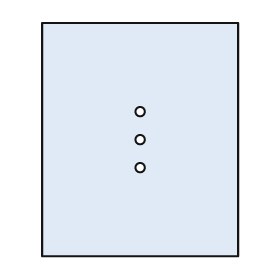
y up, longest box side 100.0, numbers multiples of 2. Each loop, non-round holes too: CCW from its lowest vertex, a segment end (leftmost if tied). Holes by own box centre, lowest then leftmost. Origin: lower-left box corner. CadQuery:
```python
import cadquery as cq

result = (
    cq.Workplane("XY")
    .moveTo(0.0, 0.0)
    .lineTo(84.0, 0.0)
    .lineTo(84.0, 100.0)
    .lineTo(0.0, 100.0)
    .close()
    .moveTo(42.0, 38.0)
    .circle(2.0)
    .moveTo(42.0, 50.0)
    .circle(2.0)
    .moveTo(42.0, 62.0)
    .circle(2.0)
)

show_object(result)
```